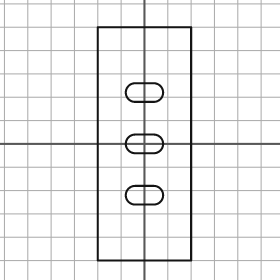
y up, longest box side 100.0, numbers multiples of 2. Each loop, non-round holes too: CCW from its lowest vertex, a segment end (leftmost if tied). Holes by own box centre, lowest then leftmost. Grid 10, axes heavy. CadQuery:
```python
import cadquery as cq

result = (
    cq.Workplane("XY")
    .moveTo(-20.0, -50.0)
    .lineTo(20.0, -50.0)
    .lineTo(20.0, 50.0)
    .lineTo(-20.0, 50.0)
    .close()
    .moveTo(-4.0, -26.0)
    .lineTo(4.0, -26.0)
    .threePointArc((8.0, -22.0), (4.0, -18.0))
    .lineTo(-4.0, -18.0)
    .threePointArc((-8.0, -22.0), (-4.0, -26.0))
    .close()
    .moveTo(-4.0, -4.0)
    .lineTo(4.0, -4.0)
    .threePointArc((8.0, 0.0), (4.0, 4.0))
    .lineTo(-4.0, 4.0)
    .threePointArc((-8.0, 0.0), (-4.0, -4.0))
    .close()
    .moveTo(-4.0, 18.0)
    .lineTo(4.0, 18.0)
    .threePointArc((8.0, 22.0), (4.0, 26.0))
    .lineTo(-4.0, 26.0)
    .threePointArc((-8.0, 22.0), (-4.0, 18.0))
    .close()
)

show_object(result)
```